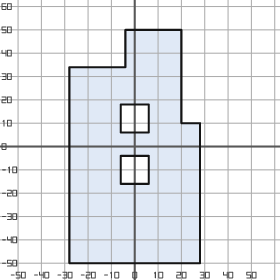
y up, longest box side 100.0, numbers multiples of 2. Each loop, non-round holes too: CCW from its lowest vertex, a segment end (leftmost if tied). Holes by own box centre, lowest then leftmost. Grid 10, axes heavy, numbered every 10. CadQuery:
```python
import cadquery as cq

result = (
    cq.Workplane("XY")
    .moveTo(-28.0, -50.0)
    .lineTo(28.0, -50.0)
    .lineTo(28.0, 10.0)
    .lineTo(20.0, 10.0)
    .lineTo(20.0, 50.0)
    .lineTo(-4.0, 50.0)
    .lineTo(-4.0, 34.0)
    .lineTo(-28.0, 34.0)
    .close()
    .moveTo(-6.0, -16.0)
    .lineTo(6.0, -16.0)
    .lineTo(6.0, -4.0)
    .lineTo(-6.0, -4.0)
    .close()
    .moveTo(-6.0, 6.0)
    .lineTo(6.0, 6.0)
    .lineTo(6.0, 18.0)
    .lineTo(-6.0, 18.0)
    .close()
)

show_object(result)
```